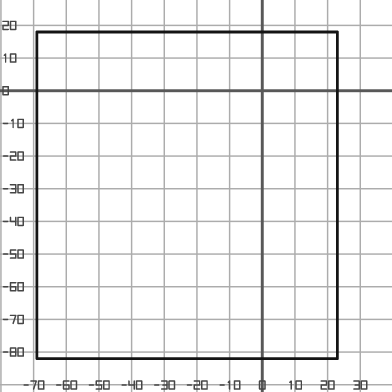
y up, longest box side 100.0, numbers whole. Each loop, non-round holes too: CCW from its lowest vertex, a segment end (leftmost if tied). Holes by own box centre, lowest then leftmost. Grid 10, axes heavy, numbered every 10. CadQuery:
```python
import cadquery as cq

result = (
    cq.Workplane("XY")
    .moveTo(-69.0, -82.0)
    .lineTo(23.0, -82.0)
    .lineTo(23.0, 18.0)
    .lineTo(-69.0, 18.0)
    .close()
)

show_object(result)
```